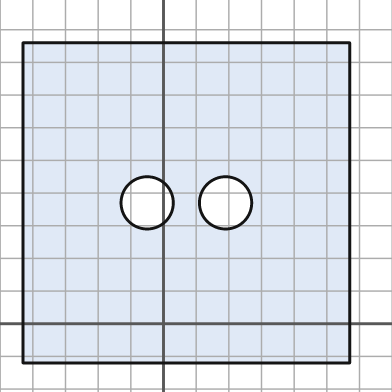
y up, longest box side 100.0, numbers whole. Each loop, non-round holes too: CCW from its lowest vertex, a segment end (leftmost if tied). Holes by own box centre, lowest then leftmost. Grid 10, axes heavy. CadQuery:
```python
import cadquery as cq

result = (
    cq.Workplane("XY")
    .moveTo(-43.0, -12.0)
    .lineTo(57.0, -12.0)
    .lineTo(57.0, 86.0)
    .lineTo(-43.0, 86.0)
    .close()
    .moveTo(-5.0, 37.0)
    .circle(8.0)
    .moveTo(19.0, 37.0)
    .circle(8.0)
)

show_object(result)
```